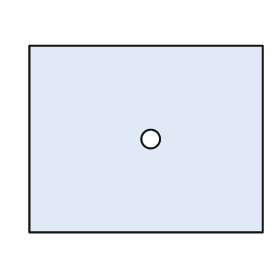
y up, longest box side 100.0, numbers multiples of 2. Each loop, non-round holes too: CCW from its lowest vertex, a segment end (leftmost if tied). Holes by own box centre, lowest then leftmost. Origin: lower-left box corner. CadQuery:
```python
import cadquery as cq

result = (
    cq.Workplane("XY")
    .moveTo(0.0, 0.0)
    .lineTo(100.0, 0.0)
    .lineTo(100.0, 80.0)
    .lineTo(0.0, 80.0)
    .close()
    .moveTo(52.0, 40.0)
    .circle(4.0)
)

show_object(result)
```